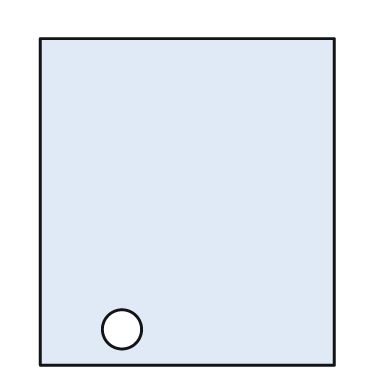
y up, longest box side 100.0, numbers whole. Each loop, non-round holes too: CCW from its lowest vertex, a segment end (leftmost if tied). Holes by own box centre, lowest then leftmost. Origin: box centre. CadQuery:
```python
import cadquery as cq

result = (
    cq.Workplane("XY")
    .moveTo(-45.0, -50.0)
    .lineTo(45.0, -50.0)
    .lineTo(45.0, 50.0)
    .lineTo(-45.0, 50.0)
    .close()
    .moveTo(-20.0, -39.0)
    .circle(6.0)
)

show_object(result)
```